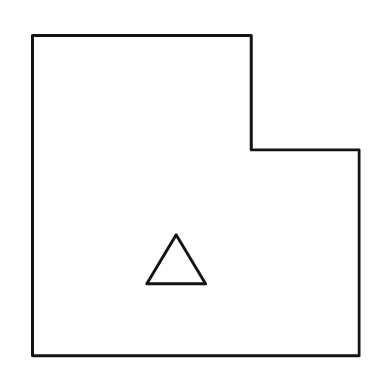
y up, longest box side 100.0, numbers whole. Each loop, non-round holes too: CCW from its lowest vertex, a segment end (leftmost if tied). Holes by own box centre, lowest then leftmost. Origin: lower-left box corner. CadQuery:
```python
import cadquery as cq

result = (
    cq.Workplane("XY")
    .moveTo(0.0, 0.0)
    .lineTo(100.0, 0.0)
    .lineTo(100.0, 63.0)
    .lineTo(67.0, 63.0)
    .lineTo(67.0, 98.0)
    .lineTo(0.0, 98.0)
    .close()
    .moveTo(35.0, 22.0)
    .lineTo(53.0, 22.0)
    .lineTo(44.0, 37.0)
    .close()
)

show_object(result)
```